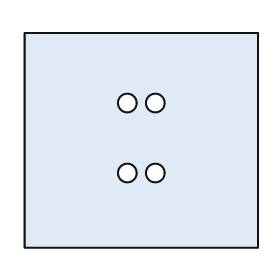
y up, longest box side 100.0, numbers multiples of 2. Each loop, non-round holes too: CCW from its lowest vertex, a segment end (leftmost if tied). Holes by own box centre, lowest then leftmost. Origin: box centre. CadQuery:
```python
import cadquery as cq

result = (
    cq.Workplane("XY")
    .moveTo(-50.0, -46.0)
    .lineTo(50.0, -46.0)
    .lineTo(50.0, 46.0)
    .lineTo(-50.0, 46.0)
    .close()
    .moveTo(-6.0, -14.0)
    .circle(4.0)
    .moveTo(6.0, -14.0)
    .circle(4.0)
    .moveTo(-6.0, 16.0)
    .circle(4.0)
    .moveTo(6.0, 16.0)
    .circle(4.0)
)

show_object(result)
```